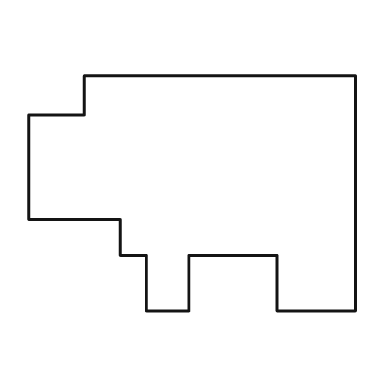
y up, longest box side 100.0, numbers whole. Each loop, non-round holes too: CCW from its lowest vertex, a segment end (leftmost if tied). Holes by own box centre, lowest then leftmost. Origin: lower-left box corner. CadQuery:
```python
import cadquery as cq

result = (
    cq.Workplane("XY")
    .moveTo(36.0, 0.0)
    .lineTo(49.0, 0.0)
    .lineTo(49.0, 17.0)
    .lineTo(76.0, 17.0)
    .lineTo(76.0, 0.0)
    .lineTo(100.0, 0.0)
    .lineTo(100.0, 72.0)
    .lineTo(17.0, 72.0)
    .lineTo(17.0, 60.0)
    .lineTo(0.0, 60.0)
    .lineTo(0.0, 28.0)
    .lineTo(28.0, 28.0)
    .lineTo(28.0, 17.0)
    .lineTo(36.0, 17.0)
    .close()
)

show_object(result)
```